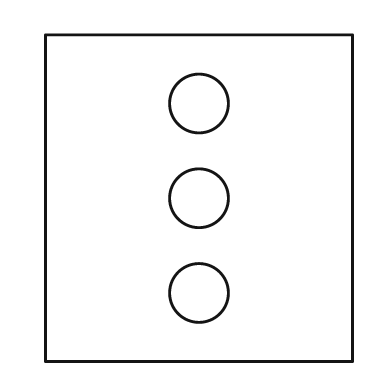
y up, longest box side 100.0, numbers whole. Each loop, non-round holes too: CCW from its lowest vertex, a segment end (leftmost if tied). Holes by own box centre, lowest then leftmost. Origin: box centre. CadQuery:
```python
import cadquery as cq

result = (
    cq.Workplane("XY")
    .moveTo(-47.0, -50.0)
    .lineTo(47.0, -50.0)
    .lineTo(47.0, 50.0)
    .lineTo(-47.0, 50.0)
    .close()
    .moveTo(0.0, -29.0)
    .circle(9.0)
    .moveTo(0.0, 0.0)
    .circle(9.0)
    .moveTo(0.0, 29.0)
    .circle(9.0)
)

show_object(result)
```